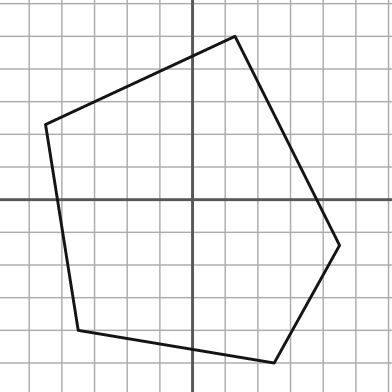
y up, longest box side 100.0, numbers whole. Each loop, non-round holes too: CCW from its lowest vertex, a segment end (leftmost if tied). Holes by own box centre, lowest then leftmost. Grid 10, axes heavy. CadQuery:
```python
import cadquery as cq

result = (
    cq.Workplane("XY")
    .moveTo(25.0, -50.0)
    .lineTo(45.0, -14.0)
    .lineTo(13.0, 50.0)
    .lineTo(-45.0, 23.0)
    .lineTo(-35.0, -40.0)
    .close()
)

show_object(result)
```